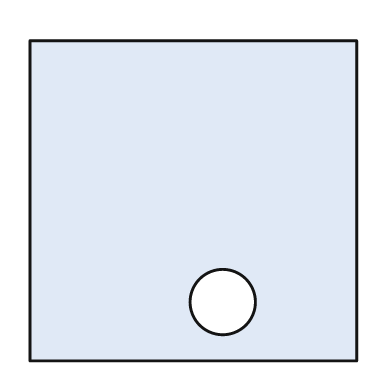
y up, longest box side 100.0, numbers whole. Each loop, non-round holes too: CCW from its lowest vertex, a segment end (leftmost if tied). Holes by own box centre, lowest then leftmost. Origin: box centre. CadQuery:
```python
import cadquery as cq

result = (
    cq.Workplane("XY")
    .moveTo(-50.0, -49.0)
    .lineTo(50.0, -49.0)
    .lineTo(50.0, 49.0)
    .lineTo(-50.0, 49.0)
    .close()
    .moveTo(9.0, -31.0)
    .circle(10.0)
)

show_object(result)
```